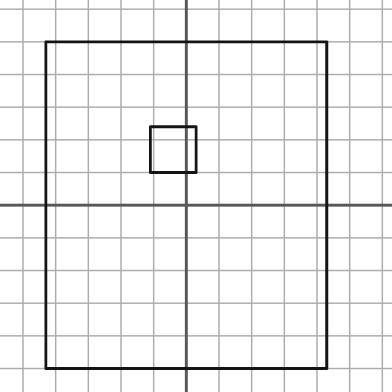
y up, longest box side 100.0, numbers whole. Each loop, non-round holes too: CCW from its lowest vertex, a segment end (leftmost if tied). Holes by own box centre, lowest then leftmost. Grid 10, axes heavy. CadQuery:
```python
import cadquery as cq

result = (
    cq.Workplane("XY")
    .moveTo(-43.0, -50.0)
    .lineTo(43.0, -50.0)
    .lineTo(43.0, 50.0)
    .lineTo(-43.0, 50.0)
    .close()
    .moveTo(-11.0, 10.0)
    .lineTo(3.0, 10.0)
    .lineTo(3.0, 24.0)
    .lineTo(-11.0, 24.0)
    .close()
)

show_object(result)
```